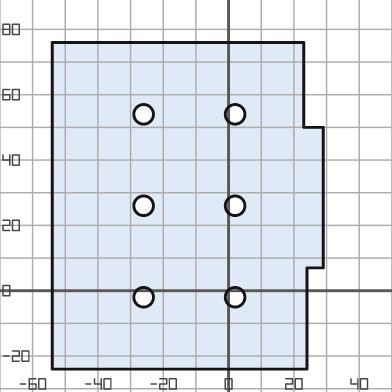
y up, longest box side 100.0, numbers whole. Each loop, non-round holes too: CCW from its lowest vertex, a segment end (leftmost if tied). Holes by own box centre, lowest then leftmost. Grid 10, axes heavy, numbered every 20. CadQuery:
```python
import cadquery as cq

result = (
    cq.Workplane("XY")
    .moveTo(-54.0, -24.0)
    .lineTo(24.0, -24.0)
    .lineTo(24.0, 7.0)
    .lineTo(29.0, 7.0)
    .lineTo(29.0, 50.0)
    .lineTo(23.0, 50.0)
    .lineTo(23.0, 76.0)
    .lineTo(-54.0, 76.0)
    .close()
    .moveTo(-26.0, -2.0)
    .circle(3.0)
    .moveTo(2.0, -2.0)
    .circle(3.0)
    .moveTo(-26.0, 26.0)
    .circle(3.0)
    .moveTo(2.0, 26.0)
    .circle(3.0)
    .moveTo(-26.0, 54.0)
    .circle(3.0)
    .moveTo(2.0, 54.0)
    .circle(3.0)
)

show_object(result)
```